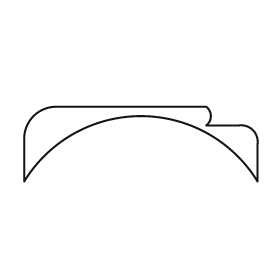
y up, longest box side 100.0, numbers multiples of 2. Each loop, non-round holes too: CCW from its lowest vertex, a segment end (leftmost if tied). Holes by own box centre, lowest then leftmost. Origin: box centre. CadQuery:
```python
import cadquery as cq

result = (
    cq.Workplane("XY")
    .moveTo(-50.0, -16.0)
    .threePointArc((0.0, 12.0), (50.0, -16.0))
    .lineTo(50.0, 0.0)
    .threePointArc((48.0, 6.0), (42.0, 8.0))
    .lineTo(28.0, 8.0)
    .threePointArc((30.0, 12.0), (28.0, 16.0))
    .lineTo(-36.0, 16.0)
    .threePointArc((-46.0, 12.0), (-50.0, 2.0))
    .close()
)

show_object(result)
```